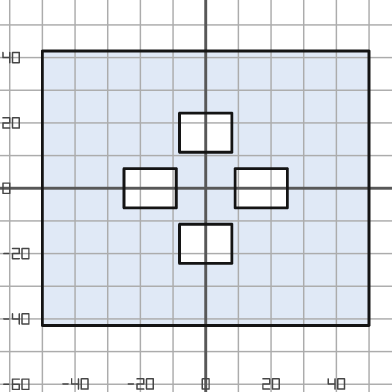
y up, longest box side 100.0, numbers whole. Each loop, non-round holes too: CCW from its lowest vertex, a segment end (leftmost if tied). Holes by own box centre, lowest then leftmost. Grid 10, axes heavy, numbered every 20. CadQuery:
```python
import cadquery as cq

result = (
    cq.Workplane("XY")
    .moveTo(-50.0, -42.0)
    .lineTo(50.0, -42.0)
    .lineTo(50.0, 42.0)
    .lineTo(-50.0, 42.0)
    .close()
    .moveTo(-8.0, -23.0)
    .lineTo(8.0, -23.0)
    .lineTo(8.0, -11.0)
    .lineTo(-8.0, -11.0)
    .close()
    .moveTo(-25.0, -6.0)
    .lineTo(-9.0, -6.0)
    .lineTo(-9.0, 6.0)
    .lineTo(-25.0, 6.0)
    .close()
    .moveTo(9.0, -6.0)
    .lineTo(25.0, -6.0)
    .lineTo(25.0, 6.0)
    .lineTo(9.0, 6.0)
    .close()
    .moveTo(-8.0, 11.0)
    .lineTo(8.0, 11.0)
    .lineTo(8.0, 23.0)
    .lineTo(-8.0, 23.0)
    .close()
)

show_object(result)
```